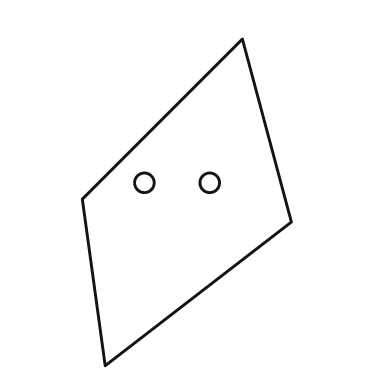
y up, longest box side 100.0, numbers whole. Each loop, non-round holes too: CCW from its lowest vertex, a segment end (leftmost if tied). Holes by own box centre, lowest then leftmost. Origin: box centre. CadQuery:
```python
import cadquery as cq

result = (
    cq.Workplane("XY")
    .moveTo(-25.0, -50.0)
    .lineTo(32.0, -6.0)
    .lineTo(17.0, 50.0)
    .lineTo(-32.0, 1.0)
    .close()
    .moveTo(-13.0, 6.0)
    .circle(3.0)
    .moveTo(7.0, 6.0)
    .circle(3.0)
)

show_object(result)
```